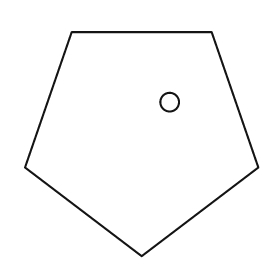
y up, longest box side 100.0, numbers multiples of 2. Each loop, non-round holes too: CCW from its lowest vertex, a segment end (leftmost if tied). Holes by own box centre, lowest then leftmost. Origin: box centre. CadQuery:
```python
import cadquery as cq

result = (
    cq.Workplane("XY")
    .moveTo(0.0, -48.0)
    .lineTo(50.0, -10.0)
    .lineTo(30.0, 48.0)
    .lineTo(-30.0, 48.0)
    .lineTo(-50.0, -10.0)
    .close()
    .moveTo(12.0, 18.0)
    .circle(4.0)
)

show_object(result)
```